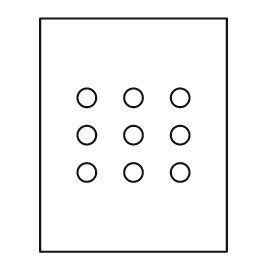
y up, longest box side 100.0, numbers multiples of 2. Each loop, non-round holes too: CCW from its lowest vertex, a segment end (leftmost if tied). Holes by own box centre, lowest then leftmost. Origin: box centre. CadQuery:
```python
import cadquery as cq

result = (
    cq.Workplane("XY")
    .moveTo(-40.0, -50.0)
    .lineTo(40.0, -50.0)
    .lineTo(40.0, 50.0)
    .lineTo(-40.0, 50.0)
    .close()
    .moveTo(-20.0, -16.0)
    .circle(4.0)
    .moveTo(0.0, -16.0)
    .circle(4.0)
    .moveTo(20.0, -16.0)
    .circle(4.0)
    .moveTo(-20.0, 0.0)
    .circle(4.0)
    .moveTo(0.0, 0.0)
    .circle(4.0)
    .moveTo(20.0, 0.0)
    .circle(4.0)
    .moveTo(-20.0, 16.0)
    .circle(4.0)
    .moveTo(0.0, 16.0)
    .circle(4.0)
    .moveTo(20.0, 16.0)
    .circle(4.0)
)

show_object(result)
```